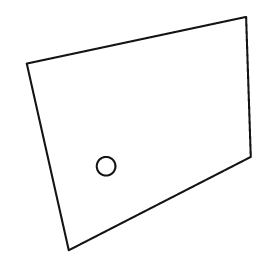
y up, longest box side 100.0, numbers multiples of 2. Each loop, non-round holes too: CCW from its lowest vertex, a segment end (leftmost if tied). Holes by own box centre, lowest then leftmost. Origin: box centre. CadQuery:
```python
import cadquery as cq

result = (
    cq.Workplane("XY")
    .moveTo(-30.0, -50.0)
    .lineTo(48.0, -10.0)
    .lineTo(46.0, 50.0)
    .lineTo(-48.0, 30.0)
    .close()
    .moveTo(-14.0, -14.0)
    .circle(4.0)
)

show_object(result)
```